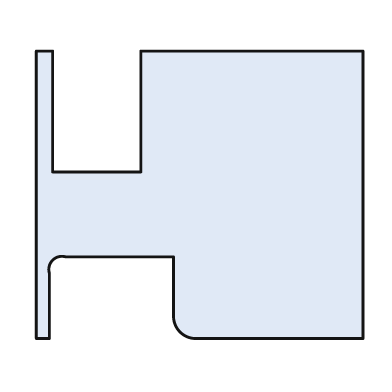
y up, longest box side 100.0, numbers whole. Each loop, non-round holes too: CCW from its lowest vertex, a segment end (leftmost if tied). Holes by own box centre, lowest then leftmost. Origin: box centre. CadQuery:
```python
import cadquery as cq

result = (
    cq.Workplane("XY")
    .moveTo(-50.0, -44.0)
    .lineTo(-46.0, -44.0)
    .lineTo(-46.0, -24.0)
    .threePointArc((-45.0, -20.0), (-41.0, -19.0))
    .lineTo(-8.0, -19.0)
    .lineTo(-8.0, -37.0)
    .threePointArc((-6.0, -42.0), (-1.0, -44.0))
    .lineTo(50.0, -44.0)
    .lineTo(50.0, 44.0)
    .lineTo(-18.0, 44.0)
    .lineTo(-18.0, 7.0)
    .lineTo(-45.0, 7.0)
    .lineTo(-45.0, 44.0)
    .lineTo(-50.0, 44.0)
    .close()
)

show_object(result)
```